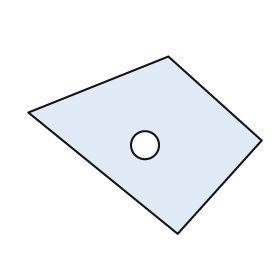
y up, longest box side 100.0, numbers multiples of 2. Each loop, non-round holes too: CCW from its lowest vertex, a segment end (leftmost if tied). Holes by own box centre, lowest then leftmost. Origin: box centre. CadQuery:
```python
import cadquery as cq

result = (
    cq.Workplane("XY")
    .moveTo(14.0, -38.0)
    .lineTo(50.0, 2.0)
    .lineTo(10.0, 38.0)
    .lineTo(-50.0, 14.0)
    .close()
    .moveTo(0.0, 0.0)
    .circle(6.0)
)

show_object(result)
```